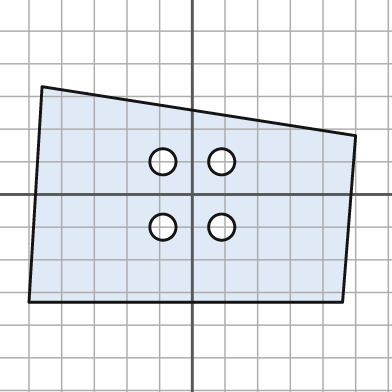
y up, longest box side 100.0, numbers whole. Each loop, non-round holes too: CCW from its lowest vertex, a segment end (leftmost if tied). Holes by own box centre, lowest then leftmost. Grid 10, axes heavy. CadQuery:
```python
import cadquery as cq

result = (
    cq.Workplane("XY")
    .moveTo(-50.0, -33.0)
    .lineTo(46.0, -33.0)
    .lineTo(50.0, 18.0)
    .lineTo(-46.0, 33.0)
    .close()
    .moveTo(-9.0, -10.0)
    .circle(4.0)
    .moveTo(9.0, -10.0)
    .circle(4.0)
    .moveTo(-9.0, 10.0)
    .circle(4.0)
    .moveTo(9.0, 10.0)
    .circle(4.0)
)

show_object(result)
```